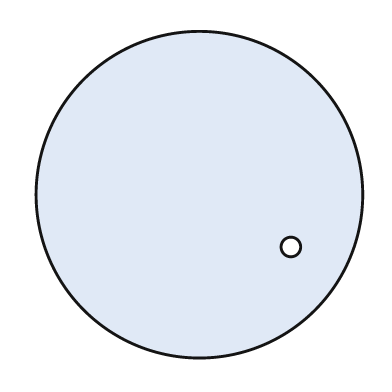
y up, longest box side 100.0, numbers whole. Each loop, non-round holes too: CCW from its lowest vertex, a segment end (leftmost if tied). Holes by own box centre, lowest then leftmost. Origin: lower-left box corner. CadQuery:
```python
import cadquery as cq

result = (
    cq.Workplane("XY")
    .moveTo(50.0, 50.0)
    .circle(50.0)
    .moveTo(78.0, 34.0)
    .circle(3.0)
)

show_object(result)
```